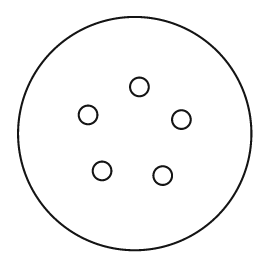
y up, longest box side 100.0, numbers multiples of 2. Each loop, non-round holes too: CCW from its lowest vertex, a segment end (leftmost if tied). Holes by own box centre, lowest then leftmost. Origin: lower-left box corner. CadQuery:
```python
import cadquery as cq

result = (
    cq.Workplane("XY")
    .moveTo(50.0, 50.0)
    .circle(50.0)
    .moveTo(62.0, 32.0)
    .circle(4.0)
    .moveTo(36.0, 34.0)
    .circle(4.0)
    .moveTo(70.0, 56.0)
    .circle(4.0)
    .moveTo(30.0, 58.0)
    .circle(4.0)
    .moveTo(52.0, 70.0)
    .circle(4.0)
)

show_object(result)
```